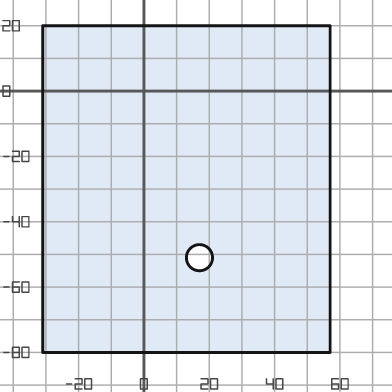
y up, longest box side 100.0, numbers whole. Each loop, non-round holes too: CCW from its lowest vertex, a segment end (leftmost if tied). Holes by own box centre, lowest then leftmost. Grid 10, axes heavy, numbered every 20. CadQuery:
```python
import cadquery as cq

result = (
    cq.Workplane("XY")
    .moveTo(-31.0, -80.0)
    .lineTo(57.0, -80.0)
    .lineTo(57.0, 20.0)
    .lineTo(-31.0, 20.0)
    .close()
    .moveTo(17.0, -51.0)
    .circle(4.0)
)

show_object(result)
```